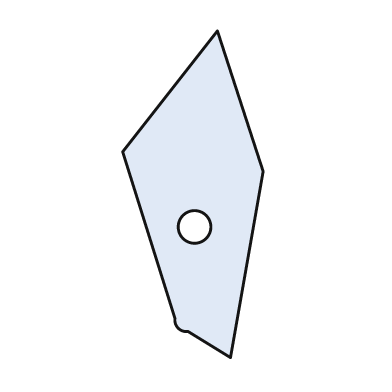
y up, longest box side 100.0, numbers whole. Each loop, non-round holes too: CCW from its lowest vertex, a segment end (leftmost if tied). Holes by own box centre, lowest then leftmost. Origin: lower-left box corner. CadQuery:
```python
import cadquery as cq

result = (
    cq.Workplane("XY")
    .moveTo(33.0, 0.0)
    .lineTo(43.0, 57.0)
    .lineTo(29.0, 100.0)
    .lineTo(0.0, 63.0)
    .lineTo(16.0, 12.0)
    .threePointArc((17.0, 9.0), (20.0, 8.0))
    .close()
    .moveTo(22.0, 40.0)
    .circle(5.0)
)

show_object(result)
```